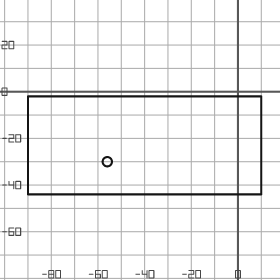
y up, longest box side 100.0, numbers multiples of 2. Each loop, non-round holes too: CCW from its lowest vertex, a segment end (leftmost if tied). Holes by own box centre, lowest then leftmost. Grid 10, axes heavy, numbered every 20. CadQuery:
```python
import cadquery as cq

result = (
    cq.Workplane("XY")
    .moveTo(-90.0, -44.0)
    .lineTo(10.0, -44.0)
    .lineTo(10.0, -2.0)
    .lineTo(-90.0, -2.0)
    .close()
    .moveTo(-56.0, -30.0)
    .circle(2.0)
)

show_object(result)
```